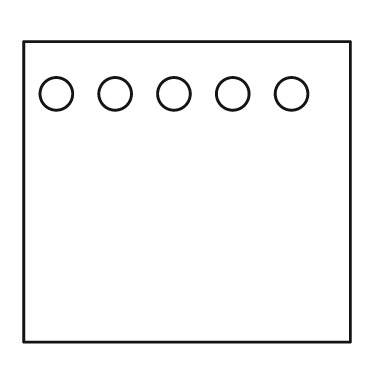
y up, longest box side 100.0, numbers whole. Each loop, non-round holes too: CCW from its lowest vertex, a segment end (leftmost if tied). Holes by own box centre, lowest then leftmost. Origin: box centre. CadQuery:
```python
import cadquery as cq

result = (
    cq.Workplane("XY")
    .moveTo(-50.0, -46.0)
    .lineTo(50.0, -46.0)
    .lineTo(50.0, 46.0)
    .lineTo(-50.0, 46.0)
    .close()
    .moveTo(-40.0, 30.0)
    .circle(5.0)
    .moveTo(-22.0, 30.0)
    .circle(5.0)
    .moveTo(-4.0, 30.0)
    .circle(5.0)
    .moveTo(14.0, 30.0)
    .circle(5.0)
    .moveTo(32.0, 30.0)
    .circle(5.0)
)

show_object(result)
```